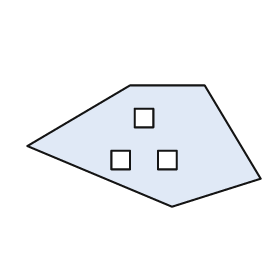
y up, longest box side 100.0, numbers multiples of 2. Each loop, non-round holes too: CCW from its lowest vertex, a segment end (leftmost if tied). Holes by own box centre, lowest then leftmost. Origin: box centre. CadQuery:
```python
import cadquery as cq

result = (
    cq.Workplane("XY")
    .moveTo(12.0, -26.0)
    .lineTo(50.0, -14.0)
    .lineTo(26.0, 26.0)
    .lineTo(-6.0, 26.0)
    .lineTo(-50.0, 0.0)
    .close()
    .moveTo(-14.0, -10.0)
    .lineTo(-6.0, -10.0)
    .lineTo(-6.0, -2.0)
    .lineTo(-14.0, -2.0)
    .close()
    .moveTo(6.0, -10.0)
    .lineTo(14.0, -10.0)
    .lineTo(14.0, -2.0)
    .lineTo(6.0, -2.0)
    .close()
    .moveTo(-4.0, 8.0)
    .lineTo(4.0, 8.0)
    .lineTo(4.0, 16.0)
    .lineTo(-4.0, 16.0)
    .close()
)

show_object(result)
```